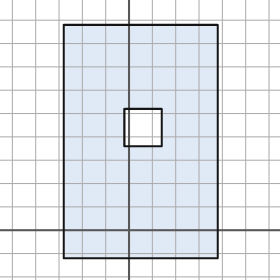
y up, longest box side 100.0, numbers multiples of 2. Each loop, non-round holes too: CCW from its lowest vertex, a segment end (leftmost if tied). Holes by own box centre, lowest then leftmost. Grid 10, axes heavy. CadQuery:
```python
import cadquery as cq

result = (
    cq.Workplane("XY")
    .moveTo(-28.0, -12.0)
    .lineTo(38.0, -12.0)
    .lineTo(38.0, 88.0)
    .lineTo(-28.0, 88.0)
    .close()
    .moveTo(-2.0, 36.0)
    .lineTo(14.0, 36.0)
    .lineTo(14.0, 52.0)
    .lineTo(-2.0, 52.0)
    .close()
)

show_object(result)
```